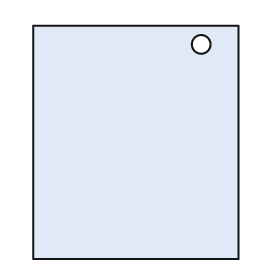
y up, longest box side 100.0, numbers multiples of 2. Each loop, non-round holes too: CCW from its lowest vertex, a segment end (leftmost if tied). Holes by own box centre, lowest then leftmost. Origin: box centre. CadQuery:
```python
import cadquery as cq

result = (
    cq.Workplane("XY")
    .moveTo(-44.0, -50.0)
    .lineTo(44.0, -50.0)
    .lineTo(44.0, 50.0)
    .lineTo(-44.0, 50.0)
    .close()
    .moveTo(28.0, 42.0)
    .circle(4.0)
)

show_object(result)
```